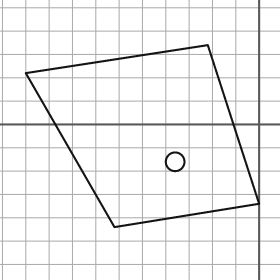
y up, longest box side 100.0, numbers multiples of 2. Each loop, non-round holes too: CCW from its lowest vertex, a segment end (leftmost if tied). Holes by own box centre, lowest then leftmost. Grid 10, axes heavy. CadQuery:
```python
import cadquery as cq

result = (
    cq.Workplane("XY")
    .moveTo(-62.0, -44.0)
    .lineTo(0.0, -34.0)
    .lineTo(-22.0, 34.0)
    .lineTo(-100.0, 22.0)
    .close()
    .moveTo(-36.0, -16.0)
    .circle(4.0)
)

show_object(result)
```